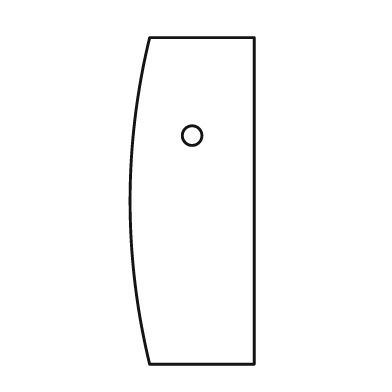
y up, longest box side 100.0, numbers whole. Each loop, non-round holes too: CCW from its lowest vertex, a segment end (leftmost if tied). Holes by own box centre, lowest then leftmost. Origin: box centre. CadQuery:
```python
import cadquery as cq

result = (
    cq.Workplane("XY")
    .moveTo(-13.0, -50.0)
    .lineTo(19.0, -50.0)
    .lineTo(19.0, 50.0)
    .lineTo(-13.0, 50.0)
    .threePointArc((-19.0, 0.0), (-13.0, -50.0))
    .close()
    .moveTo(0.0, 20.0)
    .circle(3.0)
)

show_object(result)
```